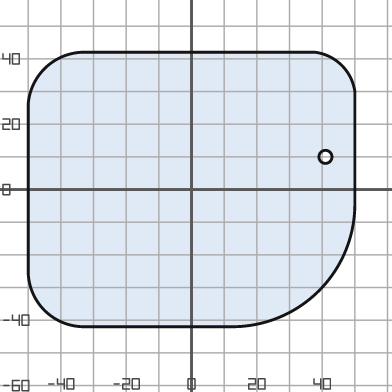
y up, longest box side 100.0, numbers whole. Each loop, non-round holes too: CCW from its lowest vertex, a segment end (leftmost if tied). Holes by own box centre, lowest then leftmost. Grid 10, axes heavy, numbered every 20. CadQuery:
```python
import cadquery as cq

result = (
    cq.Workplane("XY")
    .moveTo(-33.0, -42.0)
    .lineTo(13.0, -42.0)
    .threePointArc((39.0, -31.0), (50.0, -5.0))
    .lineTo(50.0, 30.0)
    .threePointArc((46.0, 38.0), (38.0, 42.0))
    .lineTo(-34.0, 42.0)
    .threePointArc((-45.0, 37.0), (-50.0, 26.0))
    .lineTo(-50.0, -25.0)
    .threePointArc((-45.0, -37.0), (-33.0, -42.0))
    .close()
    .moveTo(41.0, 10.0)
    .circle(2.0)
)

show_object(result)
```